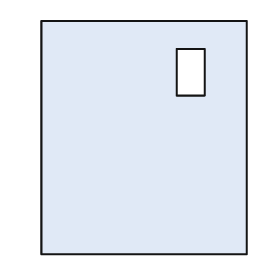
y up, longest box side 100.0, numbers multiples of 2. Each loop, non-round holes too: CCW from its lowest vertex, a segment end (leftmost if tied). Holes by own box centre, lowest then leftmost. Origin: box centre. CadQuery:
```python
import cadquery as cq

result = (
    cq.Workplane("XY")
    .moveTo(-44.0, -50.0)
    .lineTo(44.0, -50.0)
    .lineTo(44.0, 50.0)
    .lineTo(-44.0, 50.0)
    .close()
    .moveTo(14.0, 18.0)
    .lineTo(26.0, 18.0)
    .lineTo(26.0, 38.0)
    .lineTo(14.0, 38.0)
    .close()
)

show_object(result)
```